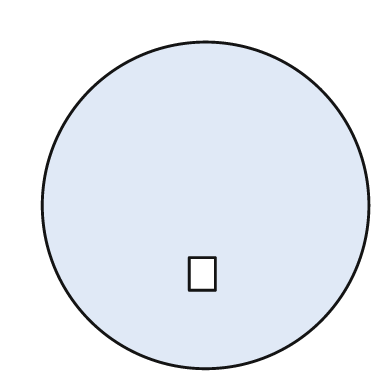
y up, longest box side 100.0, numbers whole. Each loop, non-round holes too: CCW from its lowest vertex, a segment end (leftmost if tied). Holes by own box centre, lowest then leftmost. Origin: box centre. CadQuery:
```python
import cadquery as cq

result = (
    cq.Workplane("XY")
    .moveTo(0.0, 0.0)
    .circle(50.0)
    .moveTo(-5.0, -26.0)
    .lineTo(3.0, -26.0)
    .lineTo(3.0, -16.0)
    .lineTo(-5.0, -16.0)
    .close()
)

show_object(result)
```